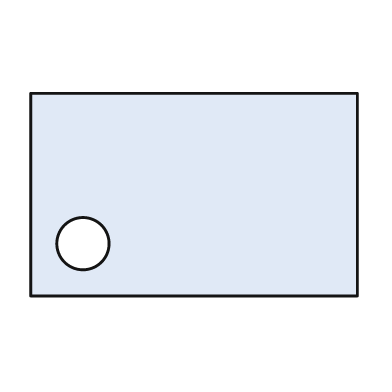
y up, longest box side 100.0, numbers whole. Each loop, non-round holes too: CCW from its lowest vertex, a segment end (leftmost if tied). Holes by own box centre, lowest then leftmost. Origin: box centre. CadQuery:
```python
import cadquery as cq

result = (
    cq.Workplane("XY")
    .moveTo(-50.0, -31.0)
    .lineTo(50.0, -31.0)
    .lineTo(50.0, 31.0)
    .lineTo(-50.0, 31.0)
    .close()
    .moveTo(-34.0, -15.0)
    .circle(8.0)
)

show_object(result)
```